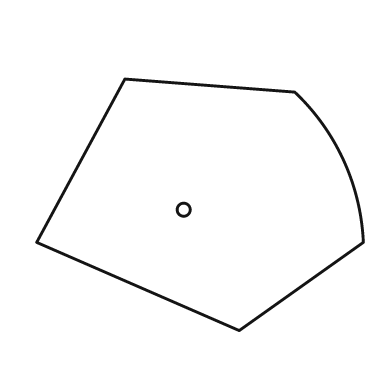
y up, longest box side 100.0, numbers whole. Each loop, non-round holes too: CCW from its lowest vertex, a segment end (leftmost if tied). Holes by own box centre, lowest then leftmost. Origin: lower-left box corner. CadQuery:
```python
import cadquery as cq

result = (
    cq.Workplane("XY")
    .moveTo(62.0, 0.0)
    .lineTo(100.0, 27.0)
    .threePointArc((94.0, 52.0), (79.0, 73.0))
    .lineTo(27.0, 77.0)
    .lineTo(0.0, 27.0)
    .close()
    .moveTo(45.0, 37.0)
    .circle(2.0)
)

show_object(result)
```